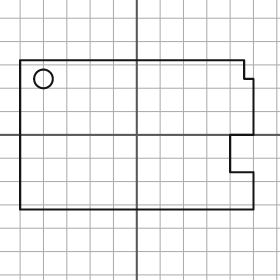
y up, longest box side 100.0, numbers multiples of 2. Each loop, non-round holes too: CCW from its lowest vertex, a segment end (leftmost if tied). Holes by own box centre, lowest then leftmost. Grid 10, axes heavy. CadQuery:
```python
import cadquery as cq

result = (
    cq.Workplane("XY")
    .moveTo(-50.0, -32.0)
    .lineTo(50.0, -32.0)
    .lineTo(50.0, -16.0)
    .lineTo(40.0, -16.0)
    .lineTo(40.0, 0.0)
    .lineTo(50.0, 0.0)
    .lineTo(50.0, 24.0)
    .lineTo(46.0, 24.0)
    .lineTo(46.0, 32.0)
    .lineTo(-50.0, 32.0)
    .close()
    .moveTo(-40.0, 24.0)
    .circle(4.0)
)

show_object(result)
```